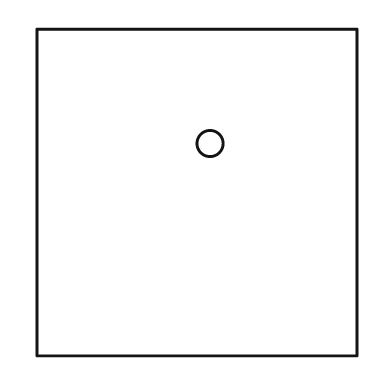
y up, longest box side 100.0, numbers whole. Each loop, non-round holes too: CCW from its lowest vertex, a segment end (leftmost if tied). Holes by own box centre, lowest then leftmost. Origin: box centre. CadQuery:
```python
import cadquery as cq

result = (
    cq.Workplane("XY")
    .moveTo(-49.0, -50.0)
    .lineTo(49.0, -50.0)
    .lineTo(49.0, 50.0)
    .lineTo(-49.0, 50.0)
    .close()
    .moveTo(4.0, 15.0)
    .circle(4.0)
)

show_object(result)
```